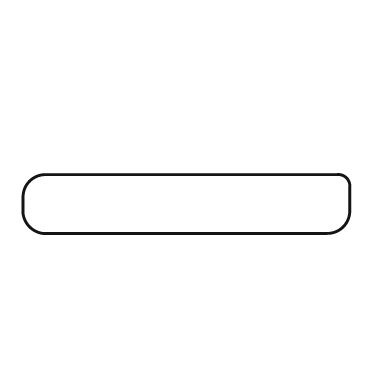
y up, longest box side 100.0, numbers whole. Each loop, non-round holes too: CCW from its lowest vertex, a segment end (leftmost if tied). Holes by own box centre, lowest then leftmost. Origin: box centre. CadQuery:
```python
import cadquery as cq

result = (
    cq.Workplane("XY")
    .moveTo(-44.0, -9.0)
    .lineTo(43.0, -9.0)
    .threePointArc((48.0, -7.0), (50.0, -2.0))
    .lineTo(50.0, 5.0)
    .threePointArc((49.0, 8.0), (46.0, 9.0))
    .lineTo(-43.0, 9.0)
    .threePointArc((-48.0, 7.0), (-50.0, 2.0))
    .lineTo(-50.0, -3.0)
    .threePointArc((-48.0, -7.0), (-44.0, -9.0))
    .close()
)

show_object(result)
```